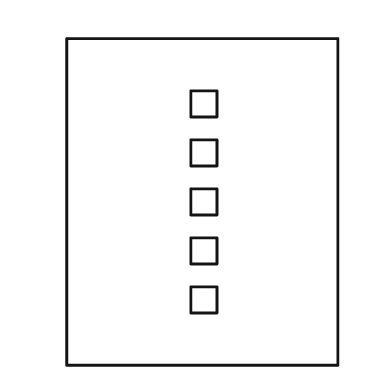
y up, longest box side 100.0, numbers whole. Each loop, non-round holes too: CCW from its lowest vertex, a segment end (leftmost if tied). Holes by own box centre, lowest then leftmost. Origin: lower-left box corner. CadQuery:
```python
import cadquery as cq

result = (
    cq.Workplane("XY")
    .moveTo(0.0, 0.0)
    .lineTo(83.0, 0.0)
    .lineTo(83.0, 100.0)
    .lineTo(0.0, 100.0)
    .close()
    .moveTo(38.0, 16.0)
    .lineTo(46.0, 16.0)
    .lineTo(46.0, 24.0)
    .lineTo(38.0, 24.0)
    .close()
    .moveTo(38.0, 31.0)
    .lineTo(46.0, 31.0)
    .lineTo(46.0, 39.0)
    .lineTo(38.0, 39.0)
    .close()
    .moveTo(38.0, 46.0)
    .lineTo(46.0, 46.0)
    .lineTo(46.0, 54.0)
    .lineTo(38.0, 54.0)
    .close()
    .moveTo(38.0, 61.0)
    .lineTo(46.0, 61.0)
    .lineTo(46.0, 69.0)
    .lineTo(38.0, 69.0)
    .close()
    .moveTo(38.0, 76.0)
    .lineTo(46.0, 76.0)
    .lineTo(46.0, 84.0)
    .lineTo(38.0, 84.0)
    .close()
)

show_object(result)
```